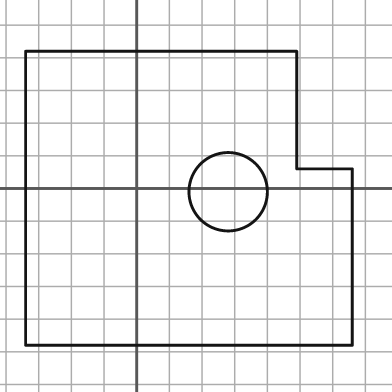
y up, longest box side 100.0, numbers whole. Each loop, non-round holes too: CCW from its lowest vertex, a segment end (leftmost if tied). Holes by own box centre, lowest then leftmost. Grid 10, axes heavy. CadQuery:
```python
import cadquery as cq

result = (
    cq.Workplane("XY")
    .moveTo(-34.0, -48.0)
    .lineTo(66.0, -48.0)
    .lineTo(66.0, 6.0)
    .lineTo(49.0, 6.0)
    .lineTo(49.0, 42.0)
    .lineTo(-34.0, 42.0)
    .close()
    .moveTo(28.0, -1.0)
    .circle(12.0)
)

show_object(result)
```